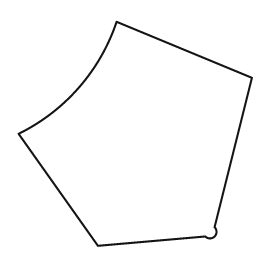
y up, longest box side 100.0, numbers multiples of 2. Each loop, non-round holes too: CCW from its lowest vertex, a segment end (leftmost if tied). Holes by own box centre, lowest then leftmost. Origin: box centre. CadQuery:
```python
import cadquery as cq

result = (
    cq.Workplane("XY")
    .moveTo(-16.0, -48.0)
    .lineTo(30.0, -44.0)
    .threePointArc((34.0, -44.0), (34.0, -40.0))
    .lineTo(50.0, 24.0)
    .lineTo(-8.0, 48.0)
    .threePointArc((-24.0, 20.0), (-50.0, 0.0))
    .close()
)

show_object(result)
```